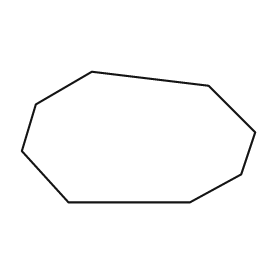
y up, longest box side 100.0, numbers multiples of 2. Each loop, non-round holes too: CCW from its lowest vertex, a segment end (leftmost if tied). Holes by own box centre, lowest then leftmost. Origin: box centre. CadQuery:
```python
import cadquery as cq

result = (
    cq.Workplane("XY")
    .moveTo(-30.0, -28.0)
    .lineTo(22.0, -28.0)
    .lineTo(44.0, -16.0)
    .lineTo(50.0, 2.0)
    .lineTo(30.0, 22.0)
    .lineTo(-20.0, 28.0)
    .lineTo(-44.0, 14.0)
    .lineTo(-50.0, -6.0)
    .close()
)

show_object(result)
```